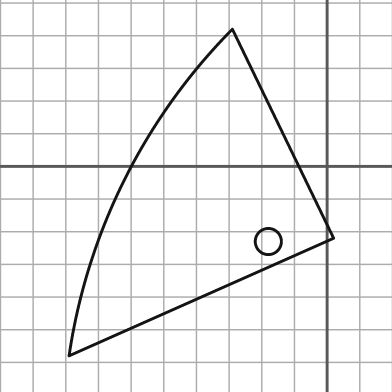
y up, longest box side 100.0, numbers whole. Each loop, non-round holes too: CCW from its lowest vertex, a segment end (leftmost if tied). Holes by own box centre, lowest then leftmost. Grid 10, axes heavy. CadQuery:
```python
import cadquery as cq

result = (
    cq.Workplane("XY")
    .moveTo(-79.0, -58.0)
    .lineTo(2.0, -22.0)
    .lineTo(-29.0, 42.0)
    .threePointArc((-62.0, -4.0), (-79.0, -58.0))
    .close()
    .moveTo(-18.0, -23.0)
    .circle(4.0)
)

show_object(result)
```